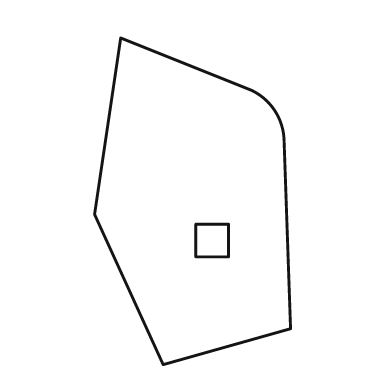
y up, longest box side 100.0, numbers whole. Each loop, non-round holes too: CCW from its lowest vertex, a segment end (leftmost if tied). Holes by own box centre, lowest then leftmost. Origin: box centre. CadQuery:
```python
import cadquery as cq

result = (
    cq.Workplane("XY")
    .moveTo(-9.0, -50.0)
    .lineTo(30.0, -39.0)
    .lineTo(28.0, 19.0)
    .threePointArc((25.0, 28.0), (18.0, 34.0))
    .lineTo(-22.0, 50.0)
    .lineTo(-30.0, -4.0)
    .close()
    .moveTo(1.0, -17.0)
    .lineTo(11.0, -17.0)
    .lineTo(11.0, -7.0)
    .lineTo(1.0, -7.0)
    .close()
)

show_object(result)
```